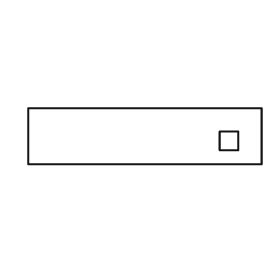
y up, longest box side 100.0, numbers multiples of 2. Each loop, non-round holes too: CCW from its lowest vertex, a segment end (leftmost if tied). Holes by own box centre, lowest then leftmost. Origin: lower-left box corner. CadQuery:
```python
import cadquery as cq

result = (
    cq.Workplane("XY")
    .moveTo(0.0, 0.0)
    .lineTo(100.0, 0.0)
    .lineTo(100.0, 24.0)
    .lineTo(0.0, 24.0)
    .close()
    .moveTo(82.0, 6.0)
    .lineTo(90.0, 6.0)
    .lineTo(90.0, 14.0)
    .lineTo(82.0, 14.0)
    .close()
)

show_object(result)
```